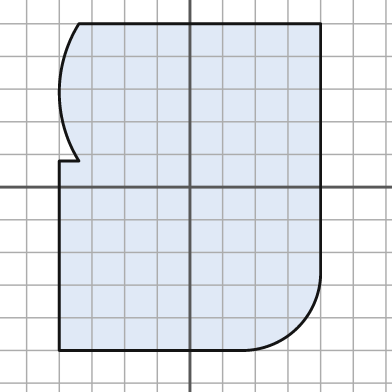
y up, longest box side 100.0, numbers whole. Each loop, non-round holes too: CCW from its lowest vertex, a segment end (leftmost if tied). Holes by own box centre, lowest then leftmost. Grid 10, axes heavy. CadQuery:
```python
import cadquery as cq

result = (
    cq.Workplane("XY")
    .moveTo(-40.0, -50.0)
    .lineTo(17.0, -50.0)
    .threePointArc((33.0, -43.0), (40.0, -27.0))
    .lineTo(40.0, 50.0)
    .lineTo(-34.0, 50.0)
    .threePointArc((-40.0, 29.0), (-34.0, 8.0))
    .lineTo(-40.0, 8.0)
    .close()
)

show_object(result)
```